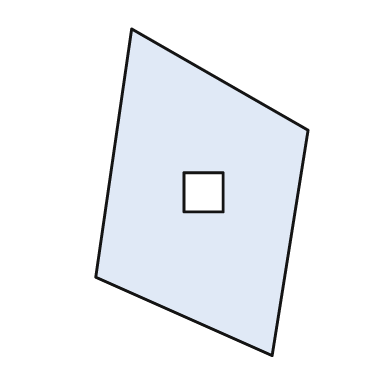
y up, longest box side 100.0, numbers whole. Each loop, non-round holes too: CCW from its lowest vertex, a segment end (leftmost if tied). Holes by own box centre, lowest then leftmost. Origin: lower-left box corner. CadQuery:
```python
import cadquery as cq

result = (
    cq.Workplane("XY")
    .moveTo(54.0, 0.0)
    .lineTo(65.0, 69.0)
    .lineTo(11.0, 100.0)
    .lineTo(0.0, 24.0)
    .close()
    .moveTo(27.0, 44.0)
    .lineTo(39.0, 44.0)
    .lineTo(39.0, 56.0)
    .lineTo(27.0, 56.0)
    .close()
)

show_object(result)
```